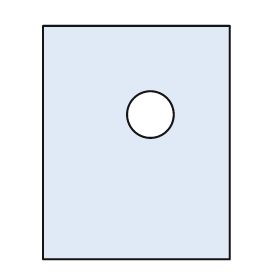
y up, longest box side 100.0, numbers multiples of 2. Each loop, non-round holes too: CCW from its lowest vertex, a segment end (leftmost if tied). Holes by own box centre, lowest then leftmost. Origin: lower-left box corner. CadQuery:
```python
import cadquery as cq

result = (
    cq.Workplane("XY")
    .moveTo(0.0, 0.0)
    .lineTo(80.0, 0.0)
    .lineTo(80.0, 100.0)
    .lineTo(0.0, 100.0)
    .close()
    .moveTo(46.0, 62.0)
    .circle(10.0)
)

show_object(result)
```